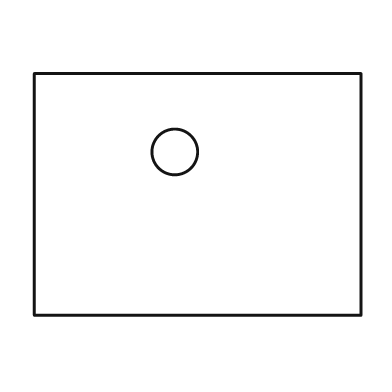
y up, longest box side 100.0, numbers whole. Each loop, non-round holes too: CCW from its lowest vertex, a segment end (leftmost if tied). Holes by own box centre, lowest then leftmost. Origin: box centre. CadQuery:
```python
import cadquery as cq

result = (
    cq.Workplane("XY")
    .moveTo(-50.0, -37.0)
    .lineTo(50.0, -37.0)
    .lineTo(50.0, 37.0)
    .lineTo(-50.0, 37.0)
    .close()
    .moveTo(-7.0, 13.0)
    .circle(7.0)
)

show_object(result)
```